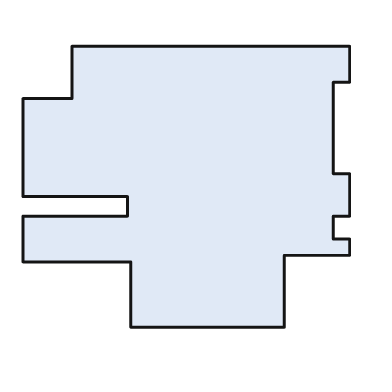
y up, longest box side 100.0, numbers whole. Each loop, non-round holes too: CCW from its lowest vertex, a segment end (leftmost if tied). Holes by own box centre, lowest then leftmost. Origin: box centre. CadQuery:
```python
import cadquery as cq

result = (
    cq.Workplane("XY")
    .moveTo(-17.0, -43.0)
    .lineTo(30.0, -43.0)
    .lineTo(30.0, -21.0)
    .lineTo(50.0, -21.0)
    .lineTo(50.0, -16.0)
    .lineTo(45.0, -16.0)
    .lineTo(45.0, -9.0)
    .lineTo(50.0, -9.0)
    .lineTo(50.0, 4.0)
    .lineTo(45.0, 4.0)
    .lineTo(45.0, 32.0)
    .lineTo(50.0, 32.0)
    .lineTo(50.0, 43.0)
    .lineTo(-35.0, 43.0)
    .lineTo(-35.0, 27.0)
    .lineTo(-50.0, 27.0)
    .lineTo(-50.0, -3.0)
    .lineTo(-18.0, -3.0)
    .lineTo(-18.0, -9.0)
    .lineTo(-50.0, -9.0)
    .lineTo(-50.0, -23.0)
    .lineTo(-17.0, -23.0)
    .close()
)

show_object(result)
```